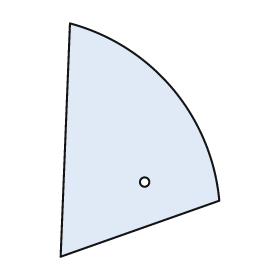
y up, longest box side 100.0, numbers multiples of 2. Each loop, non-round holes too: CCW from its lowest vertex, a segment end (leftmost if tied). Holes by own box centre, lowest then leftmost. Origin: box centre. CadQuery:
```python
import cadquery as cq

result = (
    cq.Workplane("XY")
    .moveTo(-34.0, -50.0)
    .lineTo(34.0, -26.0)
    .threePointArc((14.0, 22.0), (-30.0, 50.0))
    .close()
    .moveTo(2.0, -18.0)
    .circle(2.0)
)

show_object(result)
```